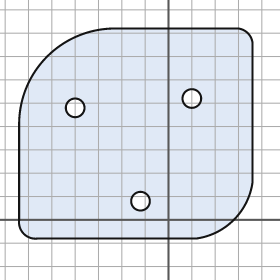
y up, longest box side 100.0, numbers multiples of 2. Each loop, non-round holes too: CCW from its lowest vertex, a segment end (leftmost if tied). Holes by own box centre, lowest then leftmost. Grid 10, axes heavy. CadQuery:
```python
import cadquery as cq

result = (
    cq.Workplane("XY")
    .moveTo(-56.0, -8.0)
    .lineTo(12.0, -8.0)
    .threePointArc((28.0, 0.0), (36.0, 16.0))
    .lineTo(36.0, 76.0)
    .threePointArc((34.0, 80.0), (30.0, 82.0))
    .lineTo(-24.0, 82.0)
    .threePointArc((-52.0, 70.0), (-64.0, 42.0))
    .lineTo(-64.0, 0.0)
    .threePointArc((-62.0, -6.0), (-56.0, -8.0))
    .close()
    .moveTo(-12.0, 8.0)
    .circle(4.0)
    .moveTo(-40.0, 48.0)
    .circle(4.0)
    .moveTo(10.0, 52.0)
    .circle(4.0)
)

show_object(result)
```